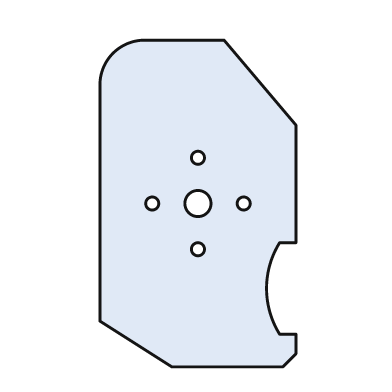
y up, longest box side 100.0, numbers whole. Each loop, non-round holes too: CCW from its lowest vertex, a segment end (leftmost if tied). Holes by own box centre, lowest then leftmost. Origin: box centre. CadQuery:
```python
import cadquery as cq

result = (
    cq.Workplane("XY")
    .moveTo(-8.0, -50.0)
    .lineTo(26.0, -50.0)
    .lineTo(30.0, -46.0)
    .lineTo(30.0, -40.0)
    .lineTo(25.0, -40.0)
    .threePointArc((21.0, -26.0), (25.0, -12.0))
    .lineTo(30.0, -12.0)
    .lineTo(30.0, 24.0)
    .lineTo(8.0, 50.0)
    .lineTo(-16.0, 50.0)
    .threePointArc((-26.0, 46.0), (-30.0, 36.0))
    .lineTo(-30.0, -36.0)
    .close()
    .moveTo(0.0, -14.0)
    .circle(2.0)
    .moveTo(-14.0, 0.0)
    .circle(2.0)
    .moveTo(0.0, 0.0)
    .circle(4.0)
    .moveTo(14.0, 0.0)
    .circle(2.0)
    .moveTo(0.0, 14.0)
    .circle(2.0)
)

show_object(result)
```